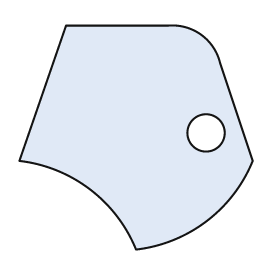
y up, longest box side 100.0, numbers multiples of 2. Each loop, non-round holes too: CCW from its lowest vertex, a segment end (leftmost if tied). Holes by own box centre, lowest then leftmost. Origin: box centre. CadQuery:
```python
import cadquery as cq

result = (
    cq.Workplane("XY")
    .moveTo(0.0, -48.0)
    .threePointArc((30.0, -36.0), (50.0, -10.0))
    .lineTo(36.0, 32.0)
    .threePointArc((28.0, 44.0), (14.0, 48.0))
    .lineTo(-30.0, 48.0)
    .lineTo(-50.0, -10.0)
    .threePointArc((-20.0, -22.0), (0.0, -48.0))
    .close()
    .moveTo(30.0, 2.0)
    .circle(8.0)
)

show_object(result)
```